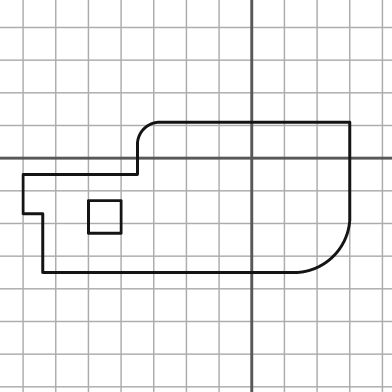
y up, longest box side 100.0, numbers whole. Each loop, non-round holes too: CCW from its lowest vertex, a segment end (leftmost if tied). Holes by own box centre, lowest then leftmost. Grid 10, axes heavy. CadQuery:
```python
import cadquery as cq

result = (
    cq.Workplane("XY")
    .moveTo(-64.0, -35.0)
    .lineTo(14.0, -35.0)
    .threePointArc((25.0, -30.0), (30.0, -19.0))
    .lineTo(30.0, 11.0)
    .lineTo(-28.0, 11.0)
    .threePointArc((-33.0, 9.0), (-35.0, 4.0))
    .lineTo(-35.0, -5.0)
    .lineTo(-70.0, -5.0)
    .lineTo(-70.0, -17.0)
    .lineTo(-64.0, -17.0)
    .close()
    .moveTo(-50.0, -23.0)
    .lineTo(-40.0, -23.0)
    .lineTo(-40.0, -13.0)
    .lineTo(-50.0, -13.0)
    .close()
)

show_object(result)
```